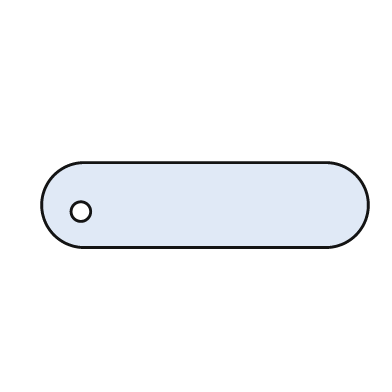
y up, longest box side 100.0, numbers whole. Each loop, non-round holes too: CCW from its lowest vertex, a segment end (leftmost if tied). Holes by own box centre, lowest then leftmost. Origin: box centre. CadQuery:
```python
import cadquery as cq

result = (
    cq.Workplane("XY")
    .moveTo(-37.0, -13.0)
    .lineTo(37.0, -13.0)
    .threePointArc((50.0, 0.0), (37.0, 13.0))
    .lineTo(-37.0, 13.0)
    .threePointArc((-50.0, 0.0), (-37.0, -13.0))
    .close()
    .moveTo(-38.0, -2.0)
    .circle(3.0)
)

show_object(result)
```